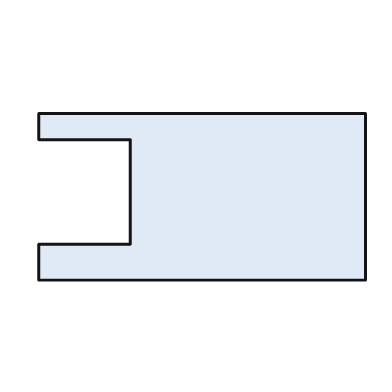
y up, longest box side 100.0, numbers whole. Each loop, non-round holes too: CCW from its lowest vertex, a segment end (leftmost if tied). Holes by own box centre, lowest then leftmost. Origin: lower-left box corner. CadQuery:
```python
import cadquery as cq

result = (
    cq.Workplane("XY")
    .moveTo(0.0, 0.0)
    .lineTo(100.0, 0.0)
    .lineTo(100.0, 51.0)
    .lineTo(0.0, 51.0)
    .lineTo(0.0, 43.0)
    .lineTo(28.0, 43.0)
    .lineTo(28.0, 11.0)
    .lineTo(0.0, 11.0)
    .close()
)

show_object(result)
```